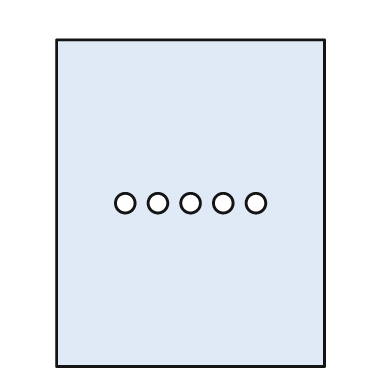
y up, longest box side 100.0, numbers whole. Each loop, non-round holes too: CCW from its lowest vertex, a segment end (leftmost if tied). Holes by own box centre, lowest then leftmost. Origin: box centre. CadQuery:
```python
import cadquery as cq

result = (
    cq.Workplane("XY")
    .moveTo(-41.0, -50.0)
    .lineTo(41.0, -50.0)
    .lineTo(41.0, 50.0)
    .lineTo(-41.0, 50.0)
    .close()
    .moveTo(-20.0, 0.0)
    .circle(3.0)
    .moveTo(-10.0, 0.0)
    .circle(3.0)
    .moveTo(0.0, 0.0)
    .circle(3.0)
    .moveTo(10.0, 0.0)
    .circle(3.0)
    .moveTo(20.0, 0.0)
    .circle(3.0)
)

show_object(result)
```